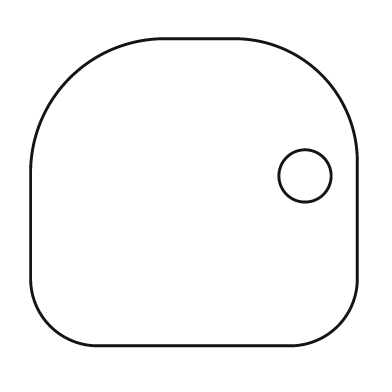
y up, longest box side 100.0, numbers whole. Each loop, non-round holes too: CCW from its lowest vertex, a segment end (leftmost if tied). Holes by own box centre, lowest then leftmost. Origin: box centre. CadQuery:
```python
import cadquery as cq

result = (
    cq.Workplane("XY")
    .moveTo(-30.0, -47.0)
    .lineTo(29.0, -47.0)
    .threePointArc((44.0, -41.0), (50.0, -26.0))
    .lineTo(50.0, 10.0)
    .threePointArc((39.0, 36.0), (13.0, 47.0))
    .lineTo(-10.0, 47.0)
    .threePointArc((-38.0, 35.0), (-50.0, 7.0))
    .lineTo(-50.0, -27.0)
    .threePointArc((-44.0, -41.0), (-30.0, -47.0))
    .close()
    .moveTo(34.0, 5.0)
    .circle(8.0)
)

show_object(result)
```